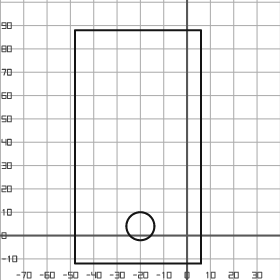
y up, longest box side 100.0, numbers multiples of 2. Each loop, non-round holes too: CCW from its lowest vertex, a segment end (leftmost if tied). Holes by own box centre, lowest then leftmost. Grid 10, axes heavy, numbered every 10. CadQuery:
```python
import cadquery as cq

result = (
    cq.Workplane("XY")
    .moveTo(-48.0, -12.0)
    .lineTo(6.0, -12.0)
    .lineTo(6.0, 88.0)
    .lineTo(-48.0, 88.0)
    .close()
    .moveTo(-20.0, 4.0)
    .circle(6.0)
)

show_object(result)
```